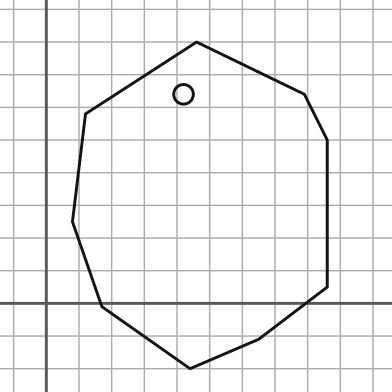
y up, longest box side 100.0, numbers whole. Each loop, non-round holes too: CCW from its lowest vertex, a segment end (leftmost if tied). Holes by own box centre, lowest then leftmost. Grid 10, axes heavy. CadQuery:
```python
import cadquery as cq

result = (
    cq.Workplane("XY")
    .moveTo(44.0, -20.0)
    .lineTo(65.0, -11.0)
    .lineTo(86.0, 5.0)
    .lineTo(86.0, 50.0)
    .lineTo(79.0, 64.0)
    .lineTo(46.0, 80.0)
    .lineTo(12.0, 58.0)
    .lineTo(8.0, 25.0)
    .lineTo(17.0, -1.0)
    .close()
    .moveTo(42.0, 64.0)
    .circle(3.0)
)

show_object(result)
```